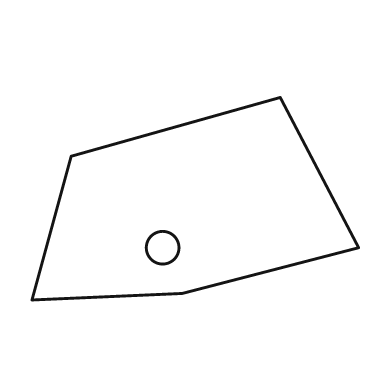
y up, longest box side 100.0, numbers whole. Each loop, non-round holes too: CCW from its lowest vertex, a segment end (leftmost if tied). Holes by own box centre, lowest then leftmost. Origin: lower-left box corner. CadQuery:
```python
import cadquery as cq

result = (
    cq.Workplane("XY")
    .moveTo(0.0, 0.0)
    .lineTo(46.0, 2.0)
    .lineTo(100.0, 16.0)
    .lineTo(76.0, 62.0)
    .lineTo(12.0, 44.0)
    .close()
    .moveTo(40.0, 16.0)
    .circle(5.0)
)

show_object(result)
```